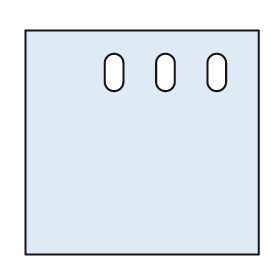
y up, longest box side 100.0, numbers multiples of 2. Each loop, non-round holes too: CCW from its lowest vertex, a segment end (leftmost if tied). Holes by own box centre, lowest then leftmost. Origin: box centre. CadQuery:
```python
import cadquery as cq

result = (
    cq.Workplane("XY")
    .moveTo(-50.0, -48.0)
    .lineTo(50.0, -48.0)
    .lineTo(50.0, 48.0)
    .lineTo(-50.0, 48.0)
    .close()
    .moveTo(-16.0, 26.0)
    .threePointArc((-12.0, 22.0), (-8.0, 26.0))
    .lineTo(-8.0, 34.0)
    .threePointArc((-12.0, 38.0), (-16.0, 34.0))
    .close()
    .moveTo(6.0, 26.0)
    .threePointArc((10.0, 22.0), (14.0, 26.0))
    .lineTo(14.0, 34.0)
    .threePointArc((10.0, 38.0), (6.0, 34.0))
    .close()
    .moveTo(28.0, 26.0)
    .threePointArc((32.0, 22.0), (36.0, 26.0))
    .lineTo(36.0, 34.0)
    .threePointArc((32.0, 38.0), (28.0, 34.0))
    .close()
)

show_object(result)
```